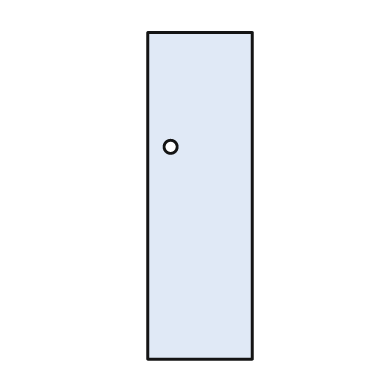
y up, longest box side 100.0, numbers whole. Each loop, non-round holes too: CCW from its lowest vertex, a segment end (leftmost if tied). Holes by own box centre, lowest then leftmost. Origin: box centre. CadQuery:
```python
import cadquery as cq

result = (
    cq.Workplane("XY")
    .moveTo(-16.0, -50.0)
    .lineTo(16.0, -50.0)
    .lineTo(16.0, 50.0)
    .lineTo(-16.0, 50.0)
    .close()
    .moveTo(-9.0, 15.0)
    .circle(2.0)
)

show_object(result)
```